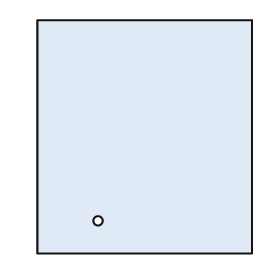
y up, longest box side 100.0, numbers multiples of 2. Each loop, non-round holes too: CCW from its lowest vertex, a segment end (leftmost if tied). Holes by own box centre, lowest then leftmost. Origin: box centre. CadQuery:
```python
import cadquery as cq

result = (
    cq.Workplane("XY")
    .moveTo(-46.0, -50.0)
    .lineTo(46.0, -50.0)
    .lineTo(46.0, 50.0)
    .lineTo(-46.0, 50.0)
    .close()
    .moveTo(-20.0, -36.0)
    .circle(2.0)
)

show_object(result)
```